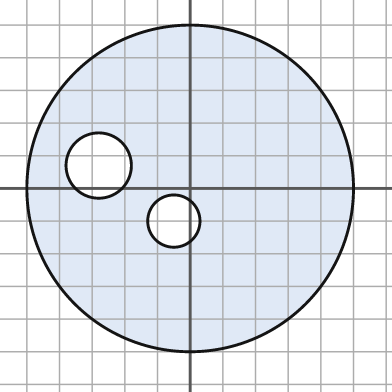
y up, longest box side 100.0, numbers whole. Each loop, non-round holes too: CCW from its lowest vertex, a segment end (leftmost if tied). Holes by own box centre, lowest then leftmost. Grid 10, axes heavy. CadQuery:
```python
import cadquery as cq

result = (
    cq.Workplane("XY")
    .moveTo(0.0, 0.0)
    .circle(50.0)
    .moveTo(-5.0, -10.0)
    .circle(8.0)
    .moveTo(-28.0, 7.0)
    .circle(10.0)
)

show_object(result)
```